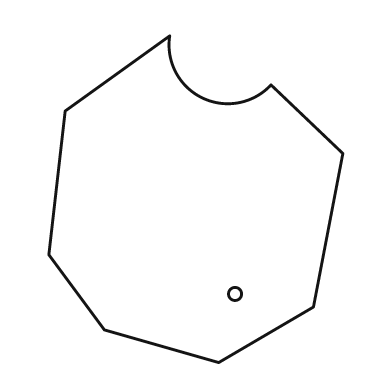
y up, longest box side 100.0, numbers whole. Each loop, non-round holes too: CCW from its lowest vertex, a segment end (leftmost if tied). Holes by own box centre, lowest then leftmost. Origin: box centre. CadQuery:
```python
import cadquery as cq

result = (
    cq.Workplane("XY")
    .moveTo(7.0, -50.0)
    .lineTo(36.0, -33.0)
    .lineTo(45.0, 14.0)
    .lineTo(23.0, 35.0)
    .threePointArc((2.0, 31.0), (-8.0, 50.0))
    .lineTo(-40.0, 27.0)
    .lineTo(-45.0, -17.0)
    .lineTo(-28.0, -40.0)
    .close()
    .moveTo(12.0, -29.0)
    .circle(2.0)
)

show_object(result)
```